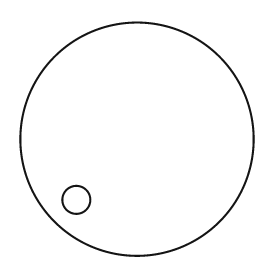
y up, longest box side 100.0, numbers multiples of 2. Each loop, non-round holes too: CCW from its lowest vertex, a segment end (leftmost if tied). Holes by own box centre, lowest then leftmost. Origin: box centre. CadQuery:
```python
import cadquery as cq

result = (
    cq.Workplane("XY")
    .moveTo(0.0, 0.0)
    .circle(50.0)
    .moveTo(-26.0, -26.0)
    .circle(6.0)
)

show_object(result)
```